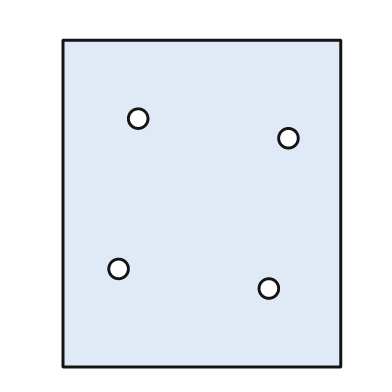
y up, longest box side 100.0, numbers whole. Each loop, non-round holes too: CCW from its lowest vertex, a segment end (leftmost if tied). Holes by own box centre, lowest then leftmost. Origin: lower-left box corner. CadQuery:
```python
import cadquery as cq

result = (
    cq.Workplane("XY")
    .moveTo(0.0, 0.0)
    .lineTo(85.0, 0.0)
    .lineTo(85.0, 100.0)
    .lineTo(0.0, 100.0)
    .close()
    .moveTo(63.0, 24.0)
    .circle(3.0)
    .moveTo(17.0, 30.0)
    .circle(3.0)
    .moveTo(69.0, 70.0)
    .circle(3.0)
    .moveTo(23.0, 76.0)
    .circle(3.0)
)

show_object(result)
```